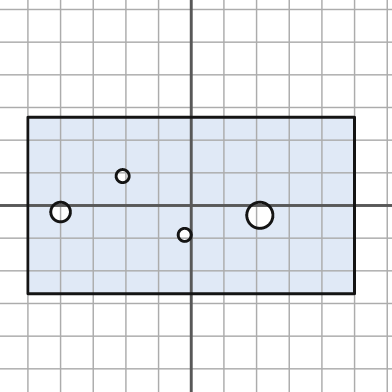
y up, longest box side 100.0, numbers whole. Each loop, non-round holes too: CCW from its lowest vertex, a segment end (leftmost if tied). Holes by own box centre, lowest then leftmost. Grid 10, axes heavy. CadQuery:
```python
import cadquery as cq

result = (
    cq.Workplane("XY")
    .moveTo(-50.0, -27.0)
    .lineTo(50.0, -27.0)
    .lineTo(50.0, 27.0)
    .lineTo(-50.0, 27.0)
    .close()
    .moveTo(-2.0, -9.0)
    .circle(2.0)
    .moveTo(21.0, -3.0)
    .circle(4.0)
    .moveTo(-40.0, -2.0)
    .circle(3.0)
    .moveTo(-21.0, 9.0)
    .circle(2.0)
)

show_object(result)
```